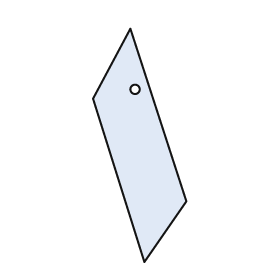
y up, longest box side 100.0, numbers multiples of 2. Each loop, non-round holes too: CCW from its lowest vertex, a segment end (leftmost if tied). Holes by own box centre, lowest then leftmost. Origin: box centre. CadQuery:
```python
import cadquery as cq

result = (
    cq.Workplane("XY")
    .moveTo(2.0, -50.0)
    .lineTo(20.0, -24.0)
    .lineTo(-4.0, 50.0)
    .lineTo(-20.0, 20.0)
    .close()
    .moveTo(-2.0, 24.0)
    .circle(2.0)
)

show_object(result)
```